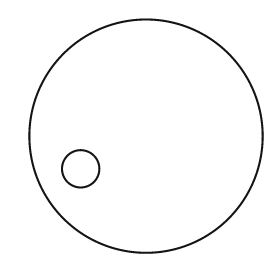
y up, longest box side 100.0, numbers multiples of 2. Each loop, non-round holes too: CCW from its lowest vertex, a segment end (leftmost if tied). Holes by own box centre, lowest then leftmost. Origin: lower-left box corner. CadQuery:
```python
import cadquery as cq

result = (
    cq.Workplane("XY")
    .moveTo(50.0, 50.0)
    .circle(50.0)
    .moveTo(22.0, 36.0)
    .circle(8.0)
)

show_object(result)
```